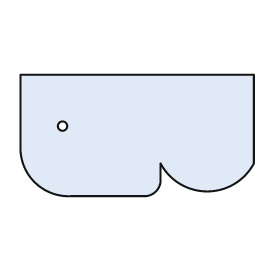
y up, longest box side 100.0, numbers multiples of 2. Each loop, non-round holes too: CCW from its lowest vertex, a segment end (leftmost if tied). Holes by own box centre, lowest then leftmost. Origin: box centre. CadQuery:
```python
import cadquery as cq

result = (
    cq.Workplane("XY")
    .moveTo(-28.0, -26.0)
    .lineTo(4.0, -26.0)
    .threePointArc((8.0, -24.0), (10.0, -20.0))
    .lineTo(10.0, -12.0)
    .threePointArc((30.0, -24.0), (50.0, -12.0))
    .lineTo(50.0, 26.0)
    .lineTo(-50.0, 26.0)
    .lineTo(-50.0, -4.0)
    .threePointArc((-44.0, -20.0), (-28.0, -26.0))
    .close()
    .moveTo(-32.0, 4.0)
    .circle(2.0)
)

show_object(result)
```